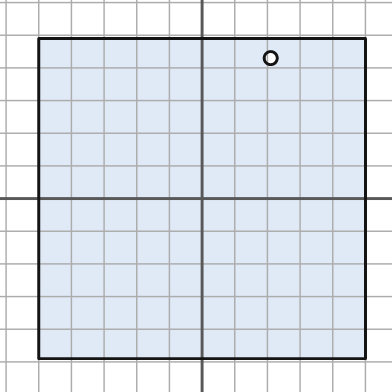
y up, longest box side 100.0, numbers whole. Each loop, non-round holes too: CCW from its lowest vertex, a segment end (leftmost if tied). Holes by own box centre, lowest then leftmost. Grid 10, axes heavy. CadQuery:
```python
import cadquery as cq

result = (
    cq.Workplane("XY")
    .moveTo(-50.0, -49.0)
    .lineTo(50.0, -49.0)
    .lineTo(50.0, 49.0)
    .lineTo(-50.0, 49.0)
    .close()
    .moveTo(21.0, 43.0)
    .circle(2.0)
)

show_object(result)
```